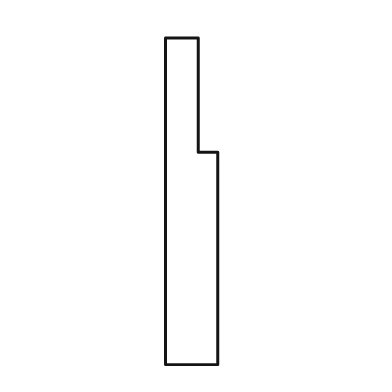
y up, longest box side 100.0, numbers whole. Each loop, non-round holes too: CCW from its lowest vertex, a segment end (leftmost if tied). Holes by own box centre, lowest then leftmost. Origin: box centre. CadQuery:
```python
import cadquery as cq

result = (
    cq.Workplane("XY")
    .moveTo(-8.0, -50.0)
    .lineTo(8.0, -50.0)
    .lineTo(8.0, 15.0)
    .lineTo(2.0, 15.0)
    .lineTo(2.0, 50.0)
    .lineTo(-8.0, 50.0)
    .close()
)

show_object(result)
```